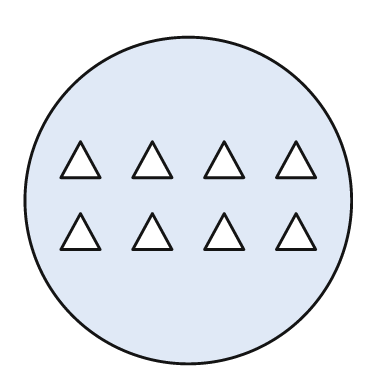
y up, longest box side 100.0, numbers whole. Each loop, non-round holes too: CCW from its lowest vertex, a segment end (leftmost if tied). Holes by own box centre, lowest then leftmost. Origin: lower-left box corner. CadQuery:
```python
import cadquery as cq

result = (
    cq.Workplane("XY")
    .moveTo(50.0, 50.0)
    .circle(50.0)
    .moveTo(11.0, 35.0)
    .lineTo(23.0, 35.0)
    .lineTo(17.0, 46.0)
    .close()
    .moveTo(33.0, 35.0)
    .lineTo(45.0, 35.0)
    .lineTo(39.0, 46.0)
    .close()
    .moveTo(55.0, 35.0)
    .lineTo(67.0, 35.0)
    .lineTo(61.0, 46.0)
    .close()
    .moveTo(77.0, 35.0)
    .lineTo(89.0, 35.0)
    .lineTo(83.0, 46.0)
    .close()
    .moveTo(11.0, 57.0)
    .lineTo(23.0, 57.0)
    .lineTo(17.0, 68.0)
    .close()
    .moveTo(33.0, 57.0)
    .lineTo(45.0, 57.0)
    .lineTo(39.0, 68.0)
    .close()
    .moveTo(55.0, 57.0)
    .lineTo(67.0, 57.0)
    .lineTo(61.0, 68.0)
    .close()
    .moveTo(77.0, 57.0)
    .lineTo(89.0, 57.0)
    .lineTo(83.0, 68.0)
    .close()
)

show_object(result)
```